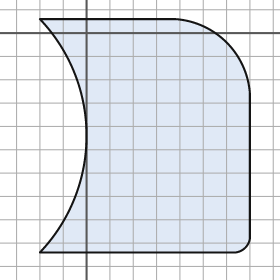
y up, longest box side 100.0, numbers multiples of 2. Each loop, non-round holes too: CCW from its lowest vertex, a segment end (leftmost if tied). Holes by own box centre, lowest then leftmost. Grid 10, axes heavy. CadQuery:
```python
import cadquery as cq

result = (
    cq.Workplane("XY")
    .moveTo(-20.0, -94.0)
    .lineTo(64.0, -94.0)
    .threePointArc((68.0, -92.0), (70.0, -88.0))
    .lineTo(70.0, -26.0)
    .threePointArc((60.0, -4.0), (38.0, 6.0))
    .lineTo(-20.0, 6.0)
    .threePointArc((0.0, -44.0), (-20.0, -94.0))
    .close()
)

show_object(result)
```